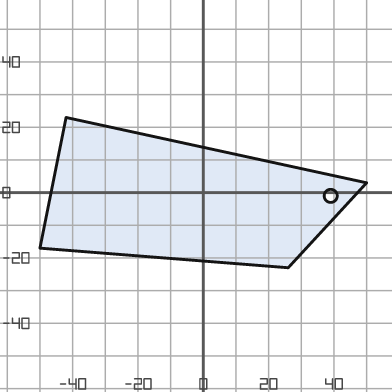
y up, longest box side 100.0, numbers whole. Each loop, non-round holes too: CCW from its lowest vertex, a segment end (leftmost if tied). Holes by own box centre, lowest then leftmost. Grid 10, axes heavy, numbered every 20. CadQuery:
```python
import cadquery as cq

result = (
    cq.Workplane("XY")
    .moveTo(26.0, -23.0)
    .lineTo(50.0, 3.0)
    .lineTo(-42.0, 23.0)
    .lineTo(-50.0, -17.0)
    .close()
    .moveTo(39.0, -1.0)
    .circle(2.0)
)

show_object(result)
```